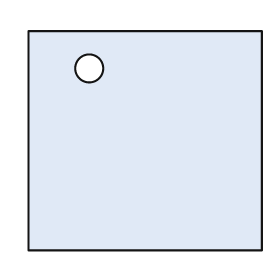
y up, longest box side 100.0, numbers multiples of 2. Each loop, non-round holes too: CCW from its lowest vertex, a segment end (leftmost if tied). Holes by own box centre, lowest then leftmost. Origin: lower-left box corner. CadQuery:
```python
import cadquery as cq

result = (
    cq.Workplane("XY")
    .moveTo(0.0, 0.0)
    .lineTo(100.0, 0.0)
    .lineTo(100.0, 94.0)
    .lineTo(0.0, 94.0)
    .close()
    .moveTo(26.0, 78.0)
    .circle(6.0)
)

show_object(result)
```